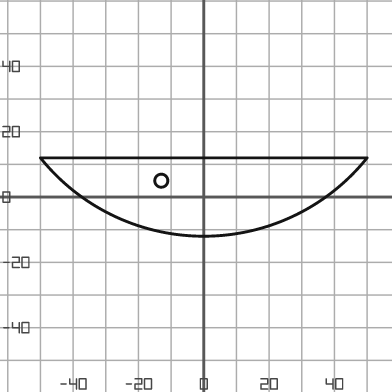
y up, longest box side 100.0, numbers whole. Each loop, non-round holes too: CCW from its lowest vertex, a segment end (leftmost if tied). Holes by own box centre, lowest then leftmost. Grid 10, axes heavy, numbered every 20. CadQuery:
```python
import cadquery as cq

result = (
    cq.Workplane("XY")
    .moveTo(-50.0, 12.0)
    .threePointArc((0.0, -12.0), (50.0, 12.0))
    .close()
    .moveTo(-13.0, 5.0)
    .circle(2.0)
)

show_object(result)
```